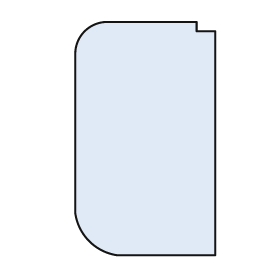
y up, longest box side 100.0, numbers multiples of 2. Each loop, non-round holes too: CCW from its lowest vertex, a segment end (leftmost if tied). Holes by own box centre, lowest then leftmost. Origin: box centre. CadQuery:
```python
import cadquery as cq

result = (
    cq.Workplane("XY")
    .moveTo(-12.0, -50.0)
    .lineTo(30.0, -50.0)
    .lineTo(30.0, 46.0)
    .lineTo(22.0, 46.0)
    .lineTo(22.0, 50.0)
    .lineTo(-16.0, 50.0)
    .threePointArc((-26.0, 46.0), (-30.0, 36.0))
    .lineTo(-30.0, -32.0)
    .threePointArc((-24.0, -44.0), (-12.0, -50.0))
    .close()
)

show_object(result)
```